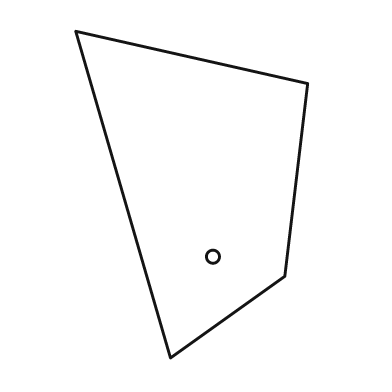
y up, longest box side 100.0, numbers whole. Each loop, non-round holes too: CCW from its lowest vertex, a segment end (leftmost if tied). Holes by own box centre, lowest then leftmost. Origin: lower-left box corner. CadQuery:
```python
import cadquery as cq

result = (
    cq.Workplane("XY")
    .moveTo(29.0, 0.0)
    .lineTo(64.0, 25.0)
    .lineTo(71.0, 84.0)
    .lineTo(0.0, 100.0)
    .close()
    .moveTo(42.0, 31.0)
    .circle(2.0)
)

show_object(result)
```